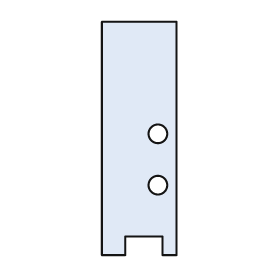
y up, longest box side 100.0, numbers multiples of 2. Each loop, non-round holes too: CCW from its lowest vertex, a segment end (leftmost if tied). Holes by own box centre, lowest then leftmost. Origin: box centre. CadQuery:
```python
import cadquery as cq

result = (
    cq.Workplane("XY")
    .moveTo(-16.0, -50.0)
    .lineTo(-6.0, -50.0)
    .lineTo(-6.0, -42.0)
    .lineTo(10.0, -42.0)
    .lineTo(10.0, -50.0)
    .lineTo(16.0, -50.0)
    .lineTo(16.0, 50.0)
    .lineTo(-16.0, 50.0)
    .close()
    .moveTo(8.0, -20.0)
    .circle(4.0)
    .moveTo(8.0, 2.0)
    .circle(4.0)
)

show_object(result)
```